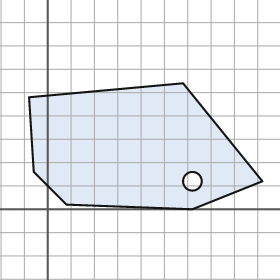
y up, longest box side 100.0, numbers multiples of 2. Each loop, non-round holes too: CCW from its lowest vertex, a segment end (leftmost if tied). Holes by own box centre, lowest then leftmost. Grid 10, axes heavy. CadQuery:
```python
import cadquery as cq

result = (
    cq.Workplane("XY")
    .moveTo(62.0, 0.0)
    .lineTo(92.0, 12.0)
    .lineTo(58.0, 54.0)
    .lineTo(-8.0, 48.0)
    .lineTo(-6.0, 16.0)
    .lineTo(8.0, 2.0)
    .close()
    .moveTo(62.0, 12.0)
    .circle(4.0)
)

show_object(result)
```